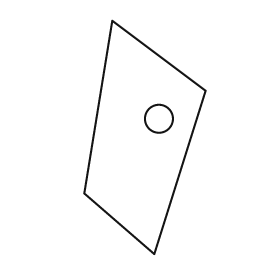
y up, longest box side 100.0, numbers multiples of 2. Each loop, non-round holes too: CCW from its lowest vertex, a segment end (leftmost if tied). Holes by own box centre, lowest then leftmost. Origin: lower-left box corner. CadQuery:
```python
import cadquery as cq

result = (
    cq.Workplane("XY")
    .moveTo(30.0, 0.0)
    .lineTo(52.0, 70.0)
    .lineTo(12.0, 100.0)
    .lineTo(0.0, 26.0)
    .close()
    .moveTo(32.0, 58.0)
    .circle(6.0)
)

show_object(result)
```